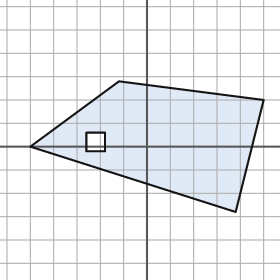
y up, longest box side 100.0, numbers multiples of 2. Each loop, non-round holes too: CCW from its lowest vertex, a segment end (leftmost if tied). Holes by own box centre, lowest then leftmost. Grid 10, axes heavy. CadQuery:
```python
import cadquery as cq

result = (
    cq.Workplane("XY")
    .moveTo(38.0, -28.0)
    .lineTo(50.0, 20.0)
    .lineTo(-12.0, 28.0)
    .lineTo(-50.0, 0.0)
    .close()
    .moveTo(-26.0, -2.0)
    .lineTo(-18.0, -2.0)
    .lineTo(-18.0, 6.0)
    .lineTo(-26.0, 6.0)
    .close()
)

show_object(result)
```